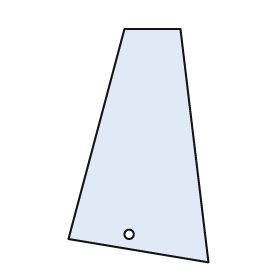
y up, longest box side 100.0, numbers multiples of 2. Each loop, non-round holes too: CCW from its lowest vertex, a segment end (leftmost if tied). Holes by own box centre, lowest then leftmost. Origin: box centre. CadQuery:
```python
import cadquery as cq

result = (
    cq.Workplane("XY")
    .moveTo(30.0, -50.0)
    .lineTo(18.0, 50.0)
    .lineTo(-6.0, 50.0)
    .lineTo(-30.0, -40.0)
    .close()
    .moveTo(-4.0, -38.0)
    .circle(2.0)
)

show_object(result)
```